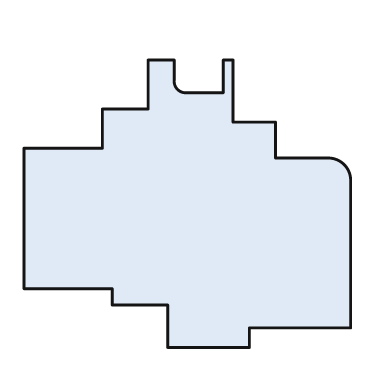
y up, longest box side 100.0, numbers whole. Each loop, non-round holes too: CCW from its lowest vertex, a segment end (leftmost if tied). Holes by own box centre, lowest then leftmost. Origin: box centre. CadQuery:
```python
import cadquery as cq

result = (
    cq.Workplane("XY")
    .moveTo(-6.0, -44.0)
    .lineTo(19.0, -44.0)
    .lineTo(19.0, -38.0)
    .lineTo(50.0, -38.0)
    .lineTo(50.0, 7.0)
    .threePointArc((48.0, 12.0), (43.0, 14.0))
    .lineTo(27.0, 14.0)
    .lineTo(27.0, 25.0)
    .lineTo(14.0, 25.0)
    .lineTo(14.0, 44.0)
    .lineTo(11.0, 44.0)
    .lineTo(11.0, 34.0)
    .lineTo(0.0, 34.0)
    .threePointArc((-3.0, 35.0), (-4.0, 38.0))
    .lineTo(-4.0, 44.0)
    .lineTo(-12.0, 44.0)
    .lineTo(-12.0, 29.0)
    .lineTo(-26.0, 29.0)
    .lineTo(-26.0, 17.0)
    .lineTo(-50.0, 17.0)
    .lineTo(-50.0, -26.0)
    .lineTo(-23.0, -26.0)
    .lineTo(-23.0, -31.0)
    .lineTo(-6.0, -31.0)
    .close()
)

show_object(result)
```